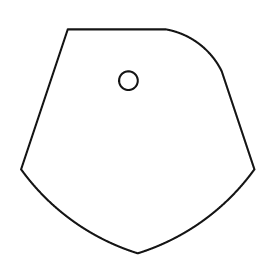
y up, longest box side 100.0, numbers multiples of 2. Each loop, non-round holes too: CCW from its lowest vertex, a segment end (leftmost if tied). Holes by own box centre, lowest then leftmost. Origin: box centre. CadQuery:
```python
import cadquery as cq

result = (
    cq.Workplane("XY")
    .moveTo(0.0, -48.0)
    .threePointArc((28.0, -34.0), (50.0, -12.0))
    .lineTo(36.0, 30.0)
    .threePointArc((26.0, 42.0), (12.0, 48.0))
    .lineTo(-30.0, 48.0)
    .lineTo(-50.0, -12.0)
    .threePointArc((-28.0, -34.0), (0.0, -48.0))
    .close()
    .moveTo(-4.0, 26.0)
    .circle(4.0)
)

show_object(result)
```